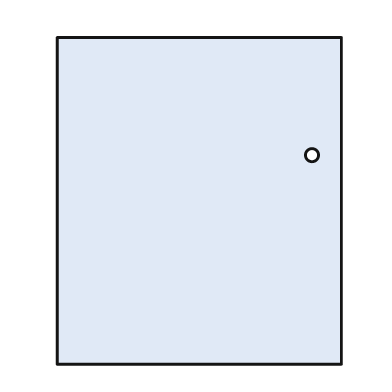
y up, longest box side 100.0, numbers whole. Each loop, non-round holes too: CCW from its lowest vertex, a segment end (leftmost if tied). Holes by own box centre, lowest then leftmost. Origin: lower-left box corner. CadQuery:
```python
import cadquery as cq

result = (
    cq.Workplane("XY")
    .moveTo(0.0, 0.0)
    .lineTo(87.0, 0.0)
    .lineTo(87.0, 100.0)
    .lineTo(0.0, 100.0)
    .close()
    .moveTo(78.0, 64.0)
    .circle(2.0)
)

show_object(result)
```